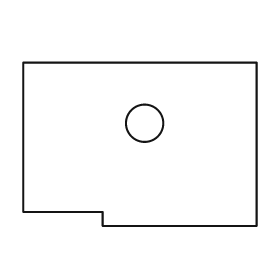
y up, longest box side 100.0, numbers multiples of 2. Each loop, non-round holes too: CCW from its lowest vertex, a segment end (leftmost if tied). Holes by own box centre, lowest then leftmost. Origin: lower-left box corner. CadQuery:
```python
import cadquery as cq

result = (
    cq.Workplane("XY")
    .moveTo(34.0, 0.0)
    .lineTo(100.0, 0.0)
    .lineTo(100.0, 70.0)
    .lineTo(0.0, 70.0)
    .lineTo(0.0, 6.0)
    .lineTo(34.0, 6.0)
    .close()
    .moveTo(52.0, 44.0)
    .circle(8.0)
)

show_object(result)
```